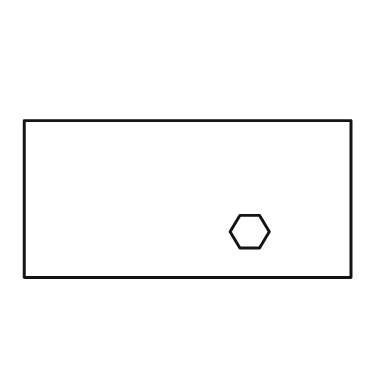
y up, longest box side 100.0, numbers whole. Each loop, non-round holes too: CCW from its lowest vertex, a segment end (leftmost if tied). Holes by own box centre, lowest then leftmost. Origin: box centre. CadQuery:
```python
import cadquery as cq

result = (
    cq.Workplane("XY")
    .moveTo(-50.0, -24.0)
    .lineTo(50.0, -24.0)
    .lineTo(50.0, 24.0)
    .lineTo(-50.0, 24.0)
    .close()
    .moveTo(16.0, -15.0)
    .lineTo(22.0, -15.0)
    .lineTo(25.0, -10.0)
    .lineTo(22.0, -5.0)
    .lineTo(16.0, -5.0)
    .lineTo(13.0, -10.0)
    .close()
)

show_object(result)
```